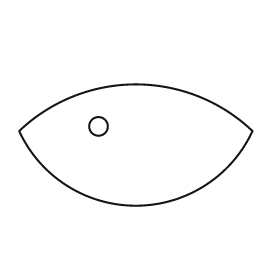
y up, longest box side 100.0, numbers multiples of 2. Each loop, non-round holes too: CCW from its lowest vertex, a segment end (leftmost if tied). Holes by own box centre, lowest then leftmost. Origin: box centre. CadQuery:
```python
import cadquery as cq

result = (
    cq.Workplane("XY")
    .moveTo(-50.0, 6.0)
    .threePointArc((0.0, -26.0), (50.0, 6.0))
    .threePointArc((0.0, 26.0), (-50.0, 6.0))
    .close()
    .moveTo(-16.0, 8.0)
    .circle(4.0)
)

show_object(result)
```